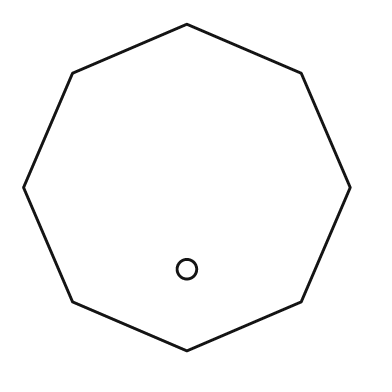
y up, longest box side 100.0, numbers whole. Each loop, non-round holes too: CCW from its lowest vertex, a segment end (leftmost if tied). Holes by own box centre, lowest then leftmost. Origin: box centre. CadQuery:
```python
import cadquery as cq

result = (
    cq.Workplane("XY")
    .moveTo(0.0, -50.0)
    .lineTo(35.0, -35.0)
    .lineTo(50.0, 0.0)
    .lineTo(35.0, 35.0)
    .lineTo(0.0, 50.0)
    .lineTo(-35.0, 35.0)
    .lineTo(-50.0, 0.0)
    .lineTo(-35.0, -35.0)
    .close()
    .moveTo(0.0, -25.0)
    .circle(3.0)
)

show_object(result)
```